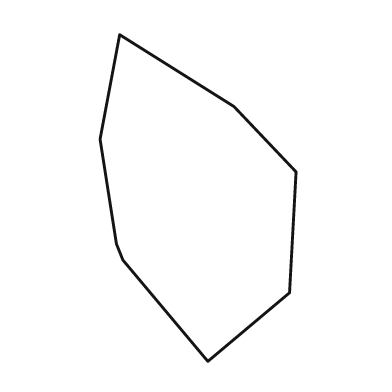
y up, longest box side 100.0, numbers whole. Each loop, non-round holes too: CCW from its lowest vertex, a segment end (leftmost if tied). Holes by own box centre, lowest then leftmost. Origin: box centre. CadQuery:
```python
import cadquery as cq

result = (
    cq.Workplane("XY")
    .moveTo(3.0, -50.0)
    .lineTo(28.0, -29.0)
    .lineTo(30.0, 8.0)
    .lineTo(11.0, 28.0)
    .lineTo(-24.0, 50.0)
    .lineTo(-30.0, 18.0)
    .lineTo(-25.0, -14.0)
    .lineTo(-23.0, -19.0)
    .close()
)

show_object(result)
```